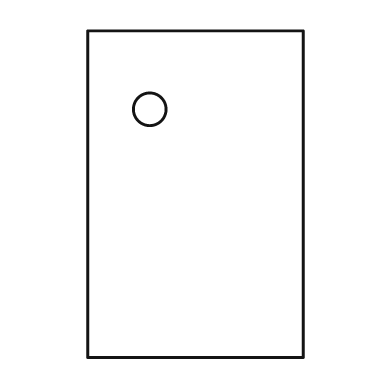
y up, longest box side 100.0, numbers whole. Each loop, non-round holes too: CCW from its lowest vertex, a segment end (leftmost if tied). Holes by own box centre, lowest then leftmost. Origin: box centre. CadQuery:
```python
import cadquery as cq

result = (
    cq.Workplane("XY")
    .moveTo(-33.0, -50.0)
    .lineTo(33.0, -50.0)
    .lineTo(33.0, 50.0)
    .lineTo(-33.0, 50.0)
    .close()
    .moveTo(-14.0, 26.0)
    .circle(5.0)
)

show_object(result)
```